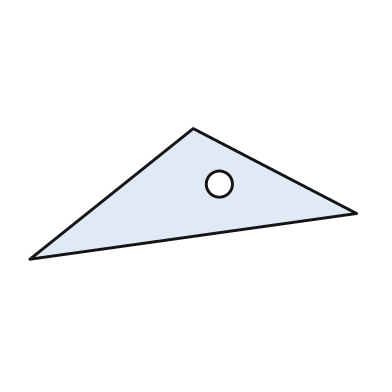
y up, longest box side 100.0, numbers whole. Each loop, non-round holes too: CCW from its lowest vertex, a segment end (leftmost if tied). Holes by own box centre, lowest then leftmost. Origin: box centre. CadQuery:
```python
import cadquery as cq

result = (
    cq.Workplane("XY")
    .moveTo(-50.0, -20.0)
    .lineTo(50.0, -6.0)
    .lineTo(0.0, 20.0)
    .close()
    .moveTo(8.0, 3.0)
    .circle(4.0)
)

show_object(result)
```